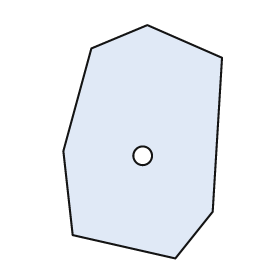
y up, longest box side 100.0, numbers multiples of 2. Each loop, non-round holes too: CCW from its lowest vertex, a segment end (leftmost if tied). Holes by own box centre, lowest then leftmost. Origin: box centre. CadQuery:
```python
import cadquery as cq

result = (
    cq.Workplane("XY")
    .moveTo(14.0, -50.0)
    .lineTo(30.0, -30.0)
    .lineTo(34.0, 36.0)
    .lineTo(2.0, 50.0)
    .lineTo(-22.0, 40.0)
    .lineTo(-34.0, -4.0)
    .lineTo(-30.0, -40.0)
    .close()
    .moveTo(0.0, -6.0)
    .circle(4.0)
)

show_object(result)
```